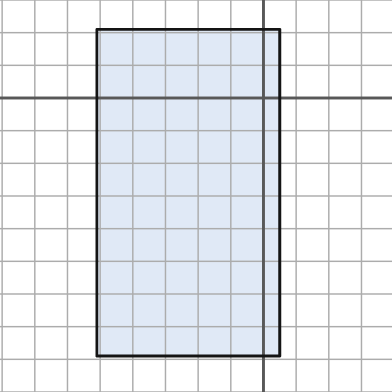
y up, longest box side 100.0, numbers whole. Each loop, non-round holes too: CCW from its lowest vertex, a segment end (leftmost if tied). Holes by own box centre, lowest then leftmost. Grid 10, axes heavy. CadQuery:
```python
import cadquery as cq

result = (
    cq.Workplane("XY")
    .moveTo(-51.0, -79.0)
    .lineTo(5.0, -79.0)
    .lineTo(5.0, 21.0)
    .lineTo(-51.0, 21.0)
    .close()
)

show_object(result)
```